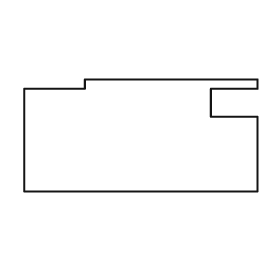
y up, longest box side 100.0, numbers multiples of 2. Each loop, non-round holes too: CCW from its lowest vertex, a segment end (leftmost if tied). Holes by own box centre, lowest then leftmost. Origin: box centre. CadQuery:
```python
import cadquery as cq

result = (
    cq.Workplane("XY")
    .moveTo(-50.0, -24.0)
    .lineTo(50.0, -24.0)
    .lineTo(50.0, 8.0)
    .lineTo(30.0, 8.0)
    .lineTo(30.0, 20.0)
    .lineTo(50.0, 20.0)
    .lineTo(50.0, 24.0)
    .lineTo(-24.0, 24.0)
    .lineTo(-24.0, 20.0)
    .lineTo(-50.0, 20.0)
    .close()
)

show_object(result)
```